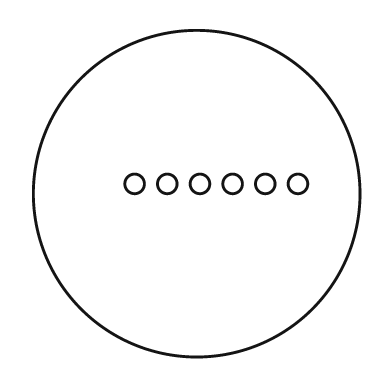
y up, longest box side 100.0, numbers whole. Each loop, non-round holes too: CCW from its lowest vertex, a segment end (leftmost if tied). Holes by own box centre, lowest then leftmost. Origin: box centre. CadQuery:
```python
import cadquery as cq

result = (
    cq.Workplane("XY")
    .moveTo(0.0, 0.0)
    .circle(50.0)
    .moveTo(-19.0, 3.0)
    .circle(3.0)
    .moveTo(-9.0, 3.0)
    .circle(3.0)
    .moveTo(1.0, 3.0)
    .circle(3.0)
    .moveTo(11.0, 3.0)
    .circle(3.0)
    .moveTo(21.0, 3.0)
    .circle(3.0)
    .moveTo(31.0, 3.0)
    .circle(3.0)
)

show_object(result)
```